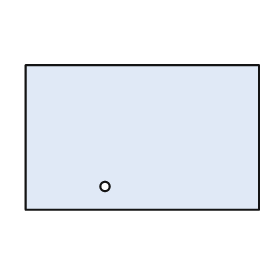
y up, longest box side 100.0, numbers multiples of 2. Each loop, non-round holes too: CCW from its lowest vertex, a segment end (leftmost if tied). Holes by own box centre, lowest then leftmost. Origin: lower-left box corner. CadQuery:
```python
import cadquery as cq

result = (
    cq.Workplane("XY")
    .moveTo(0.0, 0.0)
    .lineTo(100.0, 0.0)
    .lineTo(100.0, 62.0)
    .lineTo(0.0, 62.0)
    .close()
    .moveTo(34.0, 10.0)
    .circle(2.0)
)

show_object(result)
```